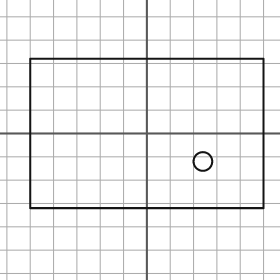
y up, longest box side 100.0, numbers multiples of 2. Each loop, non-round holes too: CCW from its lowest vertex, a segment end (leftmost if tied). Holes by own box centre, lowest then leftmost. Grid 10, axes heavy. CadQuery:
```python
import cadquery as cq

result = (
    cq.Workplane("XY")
    .moveTo(-50.0, -32.0)
    .lineTo(50.0, -32.0)
    .lineTo(50.0, 32.0)
    .lineTo(-50.0, 32.0)
    .close()
    .moveTo(24.0, -12.0)
    .circle(4.0)
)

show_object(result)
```